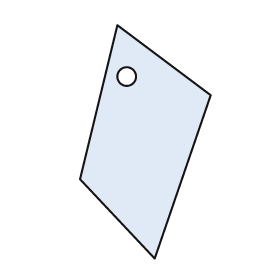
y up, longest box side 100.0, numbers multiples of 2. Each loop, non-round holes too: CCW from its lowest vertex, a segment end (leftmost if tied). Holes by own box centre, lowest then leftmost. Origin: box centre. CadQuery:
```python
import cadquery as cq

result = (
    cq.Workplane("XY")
    .moveTo(4.0, -50.0)
    .lineTo(28.0, 20.0)
    .lineTo(-12.0, 50.0)
    .lineTo(-28.0, -16.0)
    .close()
    .moveTo(-8.0, 28.0)
    .circle(4.0)
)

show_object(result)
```